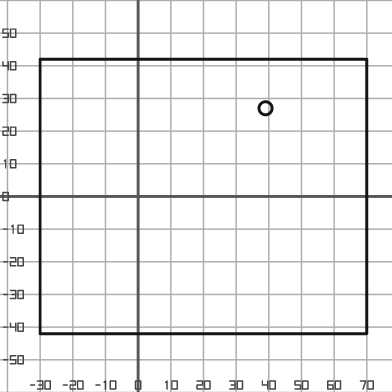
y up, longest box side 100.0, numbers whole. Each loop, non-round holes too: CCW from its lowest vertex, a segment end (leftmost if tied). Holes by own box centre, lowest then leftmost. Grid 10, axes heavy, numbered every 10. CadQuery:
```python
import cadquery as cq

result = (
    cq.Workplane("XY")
    .moveTo(-30.0, -42.0)
    .lineTo(70.0, -42.0)
    .lineTo(70.0, 42.0)
    .lineTo(-30.0, 42.0)
    .close()
    .moveTo(39.0, 27.0)
    .circle(2.0)
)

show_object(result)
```